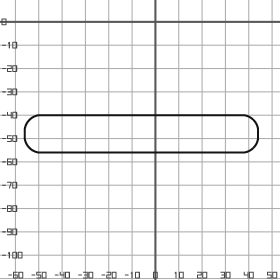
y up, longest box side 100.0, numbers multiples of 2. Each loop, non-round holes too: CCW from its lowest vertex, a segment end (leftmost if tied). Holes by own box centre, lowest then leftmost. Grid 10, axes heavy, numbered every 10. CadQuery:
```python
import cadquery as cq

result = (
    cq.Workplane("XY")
    .moveTo(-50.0, -56.0)
    .lineTo(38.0, -56.0)
    .threePointArc((42.0, -54.0), (44.0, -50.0))
    .lineTo(44.0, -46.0)
    .threePointArc((42.0, -42.0), (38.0, -40.0))
    .lineTo(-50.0, -40.0)
    .threePointArc((-54.0, -42.0), (-56.0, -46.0))
    .lineTo(-56.0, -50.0)
    .threePointArc((-54.0, -54.0), (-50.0, -56.0))
    .close()
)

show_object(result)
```